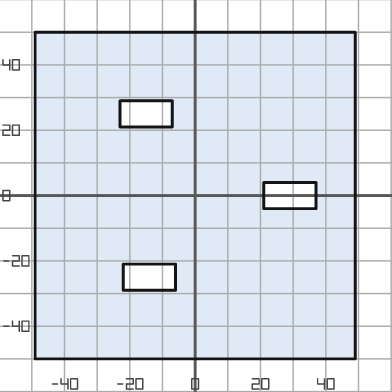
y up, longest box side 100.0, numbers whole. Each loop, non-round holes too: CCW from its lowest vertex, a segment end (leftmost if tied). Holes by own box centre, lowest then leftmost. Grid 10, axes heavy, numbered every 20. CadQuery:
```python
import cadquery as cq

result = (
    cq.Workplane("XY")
    .moveTo(-49.0, -50.0)
    .lineTo(49.0, -50.0)
    .lineTo(49.0, 50.0)
    .lineTo(-49.0, 50.0)
    .close()
    .moveTo(-22.0, -29.0)
    .lineTo(-6.0, -29.0)
    .lineTo(-6.0, -21.0)
    .lineTo(-22.0, -21.0)
    .close()
    .moveTo(21.0, -4.0)
    .lineTo(37.0, -4.0)
    .lineTo(37.0, 4.0)
    .lineTo(21.0, 4.0)
    .close()
    .moveTo(-23.0, 21.0)
    .lineTo(-7.0, 21.0)
    .lineTo(-7.0, 29.0)
    .lineTo(-23.0, 29.0)
    .close()
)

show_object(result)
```